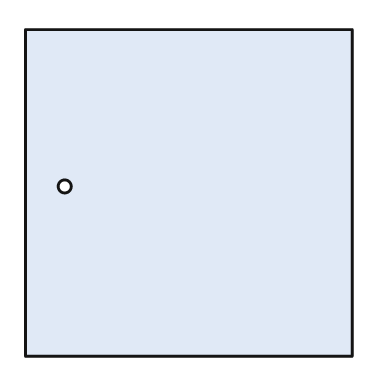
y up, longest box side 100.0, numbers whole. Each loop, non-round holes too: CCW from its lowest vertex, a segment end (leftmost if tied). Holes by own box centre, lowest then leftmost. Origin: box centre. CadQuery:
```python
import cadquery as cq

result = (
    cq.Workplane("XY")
    .moveTo(-50.0, -50.0)
    .lineTo(50.0, -50.0)
    .lineTo(50.0, 50.0)
    .lineTo(-50.0, 50.0)
    .close()
    .moveTo(-38.0, 2.0)
    .circle(2.0)
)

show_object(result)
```